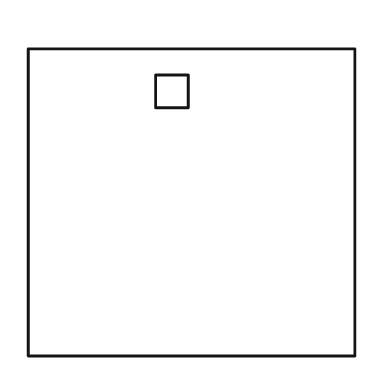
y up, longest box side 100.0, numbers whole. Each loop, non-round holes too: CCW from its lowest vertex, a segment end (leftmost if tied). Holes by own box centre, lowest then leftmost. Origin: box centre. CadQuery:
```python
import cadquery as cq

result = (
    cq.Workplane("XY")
    .moveTo(-50.0, -47.0)
    .lineTo(50.0, -47.0)
    .lineTo(50.0, 47.0)
    .lineTo(-50.0, 47.0)
    .close()
    .moveTo(-11.0, 29.0)
    .lineTo(-1.0, 29.0)
    .lineTo(-1.0, 39.0)
    .lineTo(-11.0, 39.0)
    .close()
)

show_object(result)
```